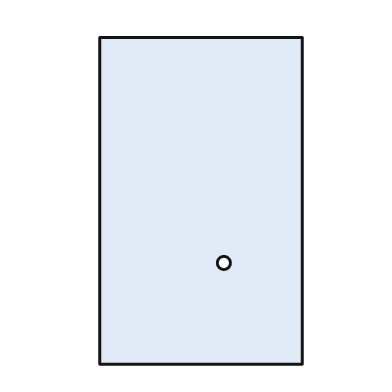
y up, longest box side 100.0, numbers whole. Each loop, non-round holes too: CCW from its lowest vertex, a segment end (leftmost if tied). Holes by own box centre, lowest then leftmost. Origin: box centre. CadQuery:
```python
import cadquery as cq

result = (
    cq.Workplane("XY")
    .moveTo(-31.0, -50.0)
    .lineTo(31.0, -50.0)
    .lineTo(31.0, 50.0)
    .lineTo(-31.0, 50.0)
    .close()
    .moveTo(7.0, -19.0)
    .circle(2.0)
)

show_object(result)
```